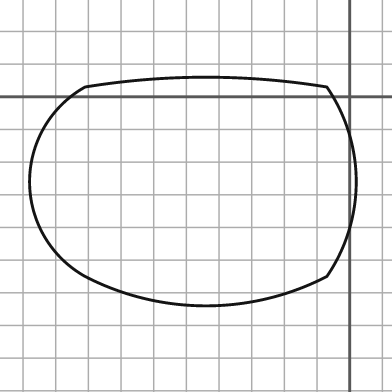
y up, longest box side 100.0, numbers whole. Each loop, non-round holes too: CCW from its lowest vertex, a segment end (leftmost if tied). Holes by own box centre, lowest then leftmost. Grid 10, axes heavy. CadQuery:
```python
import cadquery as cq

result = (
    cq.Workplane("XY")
    .moveTo(-81.0, -55.0)
    .threePointArc((-44.0, -64.0), (-7.0, -55.0))
    .threePointArc((2.0, -26.0), (-7.0, 3.0))
    .threePointArc((-44.0, 6.0), (-81.0, 3.0))
    .threePointArc((-98.0, -26.0), (-81.0, -55.0))
    .close()
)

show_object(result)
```